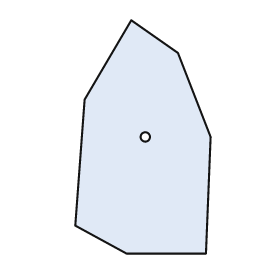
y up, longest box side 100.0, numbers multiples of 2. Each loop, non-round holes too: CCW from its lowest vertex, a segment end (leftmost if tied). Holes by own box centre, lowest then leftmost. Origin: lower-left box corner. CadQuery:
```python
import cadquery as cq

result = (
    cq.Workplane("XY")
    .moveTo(22.0, 0.0)
    .lineTo(56.0, 0.0)
    .lineTo(58.0, 50.0)
    .lineTo(44.0, 86.0)
    .lineTo(24.0, 100.0)
    .lineTo(4.0, 66.0)
    .lineTo(0.0, 12.0)
    .close()
    .moveTo(30.0, 50.0)
    .circle(2.0)
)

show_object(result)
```